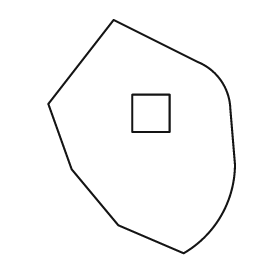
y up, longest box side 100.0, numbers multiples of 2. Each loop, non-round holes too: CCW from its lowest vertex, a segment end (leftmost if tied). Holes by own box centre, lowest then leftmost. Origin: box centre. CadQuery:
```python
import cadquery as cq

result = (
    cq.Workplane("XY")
    .moveTo(18.0, -50.0)
    .threePointArc((34.0, -34.0), (40.0, -12.0))
    .lineTo(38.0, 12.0)
    .threePointArc((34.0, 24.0), (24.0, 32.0))
    .lineTo(-12.0, 50.0)
    .lineTo(-40.0, 14.0)
    .lineTo(-30.0, -14.0)
    .lineTo(-10.0, -38.0)
    .close()
    .moveTo(-4.0, 2.0)
    .lineTo(12.0, 2.0)
    .lineTo(12.0, 18.0)
    .lineTo(-4.0, 18.0)
    .close()
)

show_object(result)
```